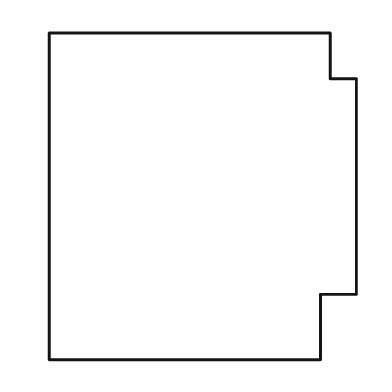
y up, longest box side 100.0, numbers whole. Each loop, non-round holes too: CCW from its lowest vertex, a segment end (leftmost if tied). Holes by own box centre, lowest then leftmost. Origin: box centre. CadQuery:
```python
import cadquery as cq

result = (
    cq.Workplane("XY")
    .moveTo(-47.0, -50.0)
    .lineTo(36.0, -50.0)
    .lineTo(36.0, -30.0)
    .lineTo(47.0, -30.0)
    .lineTo(47.0, 36.0)
    .lineTo(39.0, 36.0)
    .lineTo(39.0, 50.0)
    .lineTo(-47.0, 50.0)
    .close()
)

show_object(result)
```